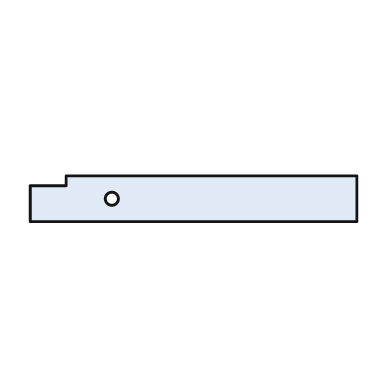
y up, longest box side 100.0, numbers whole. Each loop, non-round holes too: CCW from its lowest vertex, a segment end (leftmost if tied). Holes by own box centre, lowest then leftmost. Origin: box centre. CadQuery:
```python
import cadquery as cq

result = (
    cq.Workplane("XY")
    .moveTo(-50.0, -7.0)
    .lineTo(50.0, -7.0)
    .lineTo(50.0, 7.0)
    .lineTo(-39.0, 7.0)
    .lineTo(-39.0, 4.0)
    .lineTo(-50.0, 4.0)
    .close()
    .moveTo(-25.0, 0.0)
    .circle(2.0)
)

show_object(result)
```